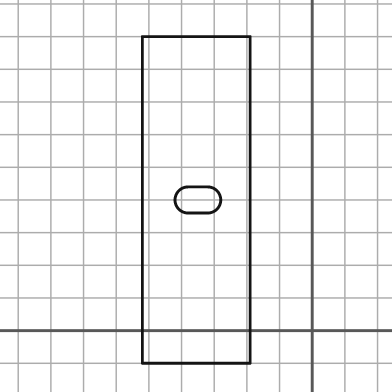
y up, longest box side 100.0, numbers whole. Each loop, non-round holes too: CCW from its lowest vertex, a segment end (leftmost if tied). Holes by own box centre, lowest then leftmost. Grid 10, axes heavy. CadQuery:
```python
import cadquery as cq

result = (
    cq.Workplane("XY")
    .moveTo(-52.0, -10.0)
    .lineTo(-19.0, -10.0)
    .lineTo(-19.0, 90.0)
    .lineTo(-52.0, 90.0)
    .close()
    .moveTo(-38.0, 36.0)
    .lineTo(-32.0, 36.0)
    .threePointArc((-28.0, 40.0), (-32.0, 44.0))
    .lineTo(-38.0, 44.0)
    .threePointArc((-42.0, 40.0), (-38.0, 36.0))
    .close()
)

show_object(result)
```